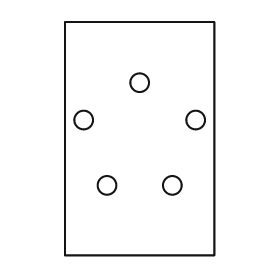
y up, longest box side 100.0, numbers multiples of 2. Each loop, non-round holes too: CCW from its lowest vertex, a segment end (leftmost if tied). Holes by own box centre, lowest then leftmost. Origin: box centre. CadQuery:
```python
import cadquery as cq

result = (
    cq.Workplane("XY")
    .moveTo(-32.0, -50.0)
    .lineTo(32.0, -50.0)
    .lineTo(32.0, 50.0)
    .lineTo(-32.0, 50.0)
    .close()
    .moveTo(-14.0, -20.0)
    .circle(4.0)
    .moveTo(14.0, -20.0)
    .circle(4.0)
    .moveTo(-24.0, 8.0)
    .circle(4.0)
    .moveTo(24.0, 8.0)
    .circle(4.0)
    .moveTo(0.0, 24.0)
    .circle(4.0)
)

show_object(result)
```